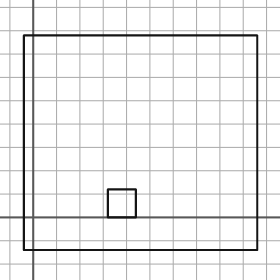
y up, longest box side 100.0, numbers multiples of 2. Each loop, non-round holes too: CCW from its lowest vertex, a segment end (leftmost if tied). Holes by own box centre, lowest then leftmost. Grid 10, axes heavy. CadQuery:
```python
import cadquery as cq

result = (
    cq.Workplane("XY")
    .moveTo(-4.0, -14.0)
    .lineTo(96.0, -14.0)
    .lineTo(96.0, 78.0)
    .lineTo(-4.0, 78.0)
    .close()
    .moveTo(32.0, 0.0)
    .lineTo(44.0, 0.0)
    .lineTo(44.0, 12.0)
    .lineTo(32.0, 12.0)
    .close()
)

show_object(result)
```